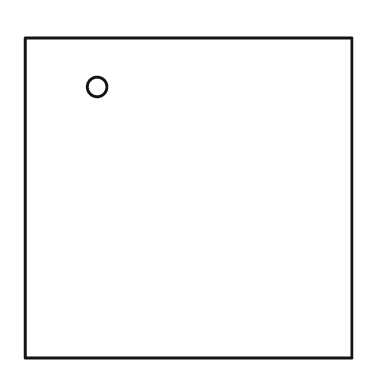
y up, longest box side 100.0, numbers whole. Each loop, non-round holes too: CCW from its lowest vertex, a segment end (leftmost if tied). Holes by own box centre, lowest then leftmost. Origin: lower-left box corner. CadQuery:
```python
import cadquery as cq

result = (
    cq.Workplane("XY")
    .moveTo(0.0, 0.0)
    .lineTo(100.0, 0.0)
    .lineTo(100.0, 98.0)
    .lineTo(0.0, 98.0)
    .close()
    .moveTo(22.0, 83.0)
    .circle(3.0)
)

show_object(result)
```